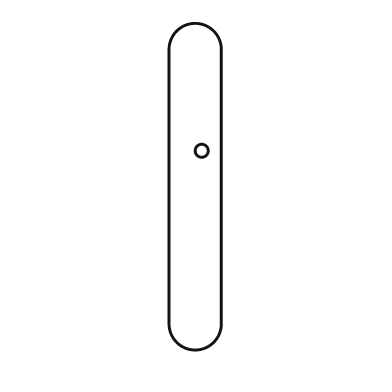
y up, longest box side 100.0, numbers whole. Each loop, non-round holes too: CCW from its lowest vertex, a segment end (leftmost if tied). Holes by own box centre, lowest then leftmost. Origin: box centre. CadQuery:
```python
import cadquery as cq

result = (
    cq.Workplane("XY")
    .moveTo(-8.0, -42.0)
    .threePointArc((0.0, -50.0), (8.0, -42.0))
    .lineTo(8.0, 42.0)
    .threePointArc((0.0, 50.0), (-8.0, 42.0))
    .close()
    .moveTo(2.0, 11.0)
    .circle(2.0)
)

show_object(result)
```